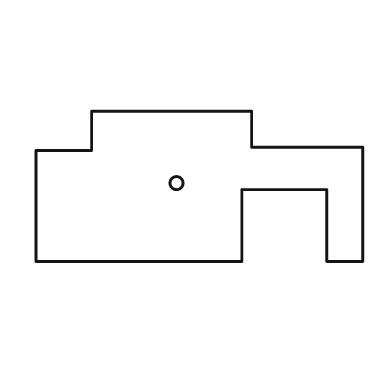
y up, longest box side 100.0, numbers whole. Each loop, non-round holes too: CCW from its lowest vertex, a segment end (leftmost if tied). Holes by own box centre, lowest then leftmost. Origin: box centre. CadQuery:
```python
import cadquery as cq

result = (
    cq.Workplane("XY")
    .moveTo(-50.0, -23.0)
    .lineTo(13.0, -23.0)
    .lineTo(13.0, -1.0)
    .lineTo(39.0, -1.0)
    .lineTo(39.0, -23.0)
    .lineTo(50.0, -23.0)
    .lineTo(50.0, 12.0)
    .lineTo(16.0, 12.0)
    .lineTo(16.0, 23.0)
    .lineTo(-33.0, 23.0)
    .lineTo(-33.0, 11.0)
    .lineTo(-50.0, 11.0)
    .close()
    .moveTo(-7.0, 1.0)
    .circle(2.0)
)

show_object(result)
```